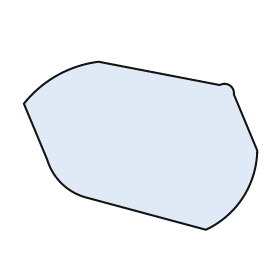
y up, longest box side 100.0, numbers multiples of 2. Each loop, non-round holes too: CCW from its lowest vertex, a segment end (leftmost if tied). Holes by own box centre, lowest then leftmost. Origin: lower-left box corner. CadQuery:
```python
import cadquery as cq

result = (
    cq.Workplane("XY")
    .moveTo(78.0, 0.0)
    .threePointArc((94.0, 14.0), (100.0, 34.0))
    .lineTo(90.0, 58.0)
    .threePointArc((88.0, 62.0), (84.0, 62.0))
    .lineTo(32.0, 72.0)
    .threePointArc((14.0, 66.0), (0.0, 54.0))
    .lineTo(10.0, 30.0)
    .threePointArc((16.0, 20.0), (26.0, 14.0))
    .close()
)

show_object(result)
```